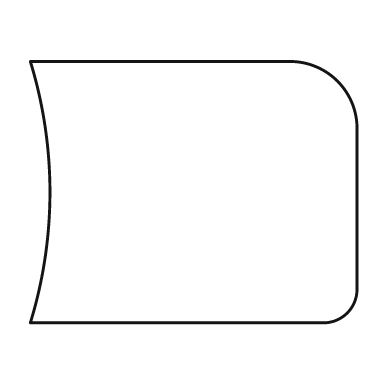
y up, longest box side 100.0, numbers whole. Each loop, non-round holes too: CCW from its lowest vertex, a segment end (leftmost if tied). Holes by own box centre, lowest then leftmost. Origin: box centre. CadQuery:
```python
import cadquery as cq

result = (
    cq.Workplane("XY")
    .moveTo(-50.0, -40.0)
    .lineTo(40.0, -40.0)
    .threePointArc((47.0, -37.0), (50.0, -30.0))
    .lineTo(50.0, 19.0)
    .threePointArc((44.0, 34.0), (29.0, 40.0))
    .lineTo(-50.0, 40.0)
    .threePointArc((-44.0, 0.0), (-50.0, -40.0))
    .close()
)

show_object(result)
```